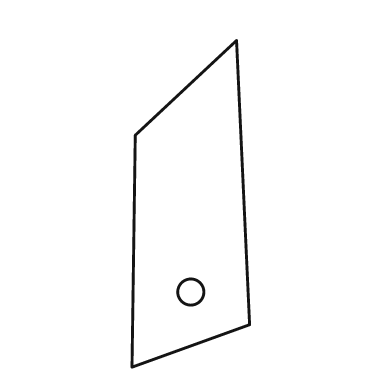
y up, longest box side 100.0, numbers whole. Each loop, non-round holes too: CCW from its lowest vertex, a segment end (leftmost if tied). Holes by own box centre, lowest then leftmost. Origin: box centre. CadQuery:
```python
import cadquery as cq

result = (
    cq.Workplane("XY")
    .moveTo(-18.0, -50.0)
    .lineTo(18.0, -37.0)
    .lineTo(14.0, 50.0)
    .lineTo(-17.0, 21.0)
    .close()
    .moveTo(0.0, -27.0)
    .circle(4.0)
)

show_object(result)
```